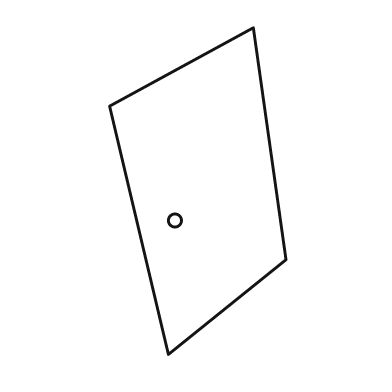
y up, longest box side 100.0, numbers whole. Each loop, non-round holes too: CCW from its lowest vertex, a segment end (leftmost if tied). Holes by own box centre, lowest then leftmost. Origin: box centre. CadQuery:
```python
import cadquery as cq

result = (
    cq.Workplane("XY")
    .moveTo(-9.0, -50.0)
    .lineTo(27.0, -21.0)
    .lineTo(17.0, 50.0)
    .lineTo(-27.0, 26.0)
    .close()
    .moveTo(-7.0, -9.0)
    .circle(2.0)
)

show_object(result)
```